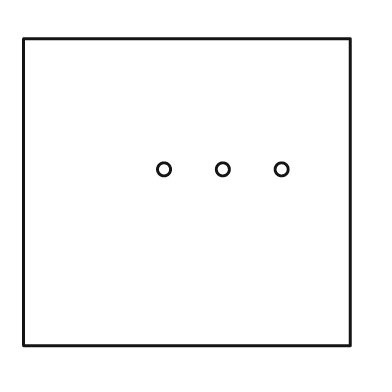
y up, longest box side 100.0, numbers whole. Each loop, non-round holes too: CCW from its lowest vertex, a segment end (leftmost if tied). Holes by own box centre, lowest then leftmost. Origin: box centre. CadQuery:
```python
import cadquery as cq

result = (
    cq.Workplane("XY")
    .moveTo(-50.0, -47.0)
    .lineTo(50.0, -47.0)
    .lineTo(50.0, 47.0)
    .lineTo(-50.0, 47.0)
    .close()
    .moveTo(-7.0, 7.0)
    .circle(2.0)
    .moveTo(11.0, 7.0)
    .circle(2.0)
    .moveTo(29.0, 7.0)
    .circle(2.0)
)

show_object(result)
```